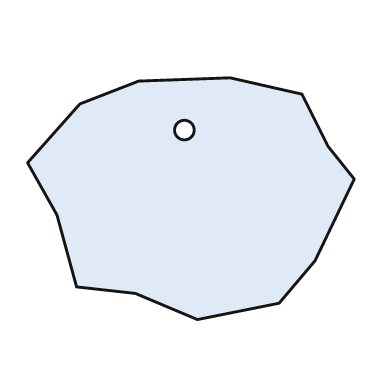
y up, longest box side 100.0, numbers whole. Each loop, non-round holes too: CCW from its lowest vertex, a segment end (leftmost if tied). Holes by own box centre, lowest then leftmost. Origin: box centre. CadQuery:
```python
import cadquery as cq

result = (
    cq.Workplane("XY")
    .moveTo(2.0, -37.0)
    .lineTo(27.0, -32.0)
    .lineTo(38.0, -19.0)
    .lineTo(50.0, 6.0)
    .lineTo(42.0, 16.0)
    .lineTo(34.0, 32.0)
    .lineTo(12.0, 37.0)
    .lineTo(-16.0, 36.0)
    .lineTo(-34.0, 29.0)
    .lineTo(-50.0, 11.0)
    .lineTo(-41.0, -5.0)
    .lineTo(-35.0, -27.0)
    .lineTo(-17.0, -29.0)
    .close()
    .moveTo(-2.0, 21.0)
    .circle(3.0)
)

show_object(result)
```